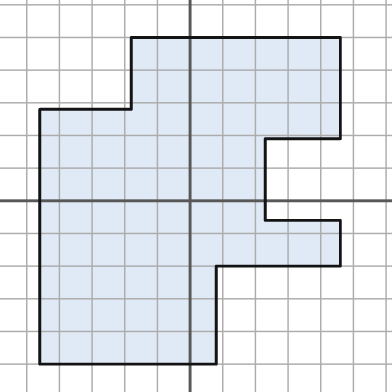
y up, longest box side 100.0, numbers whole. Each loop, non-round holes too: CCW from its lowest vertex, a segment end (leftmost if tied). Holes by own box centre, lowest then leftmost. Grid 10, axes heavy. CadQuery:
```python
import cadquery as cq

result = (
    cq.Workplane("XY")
    .moveTo(-46.0, -50.0)
    .lineTo(8.0, -50.0)
    .lineTo(8.0, -20.0)
    .lineTo(46.0, -20.0)
    .lineTo(46.0, -6.0)
    .lineTo(23.0, -6.0)
    .lineTo(23.0, 19.0)
    .lineTo(46.0, 19.0)
    .lineTo(46.0, 50.0)
    .lineTo(-18.0, 50.0)
    .lineTo(-18.0, 28.0)
    .lineTo(-46.0, 28.0)
    .close()
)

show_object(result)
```